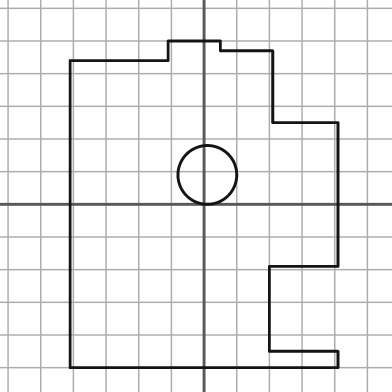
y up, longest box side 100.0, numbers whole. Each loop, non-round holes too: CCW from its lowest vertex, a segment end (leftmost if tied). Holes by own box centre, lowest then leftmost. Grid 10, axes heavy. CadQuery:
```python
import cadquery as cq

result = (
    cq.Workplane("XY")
    .moveTo(-41.0, -50.0)
    .lineTo(41.0, -50.0)
    .lineTo(41.0, -45.0)
    .lineTo(20.0, -45.0)
    .lineTo(20.0, -19.0)
    .lineTo(41.0, -19.0)
    .lineTo(41.0, 25.0)
    .lineTo(21.0, 25.0)
    .lineTo(21.0, 47.0)
    .lineTo(5.0, 47.0)
    .lineTo(5.0, 50.0)
    .lineTo(-11.0, 50.0)
    .lineTo(-11.0, 44.0)
    .lineTo(-41.0, 44.0)
    .close()
    .moveTo(1.0, 9.0)
    .circle(9.0)
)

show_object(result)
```